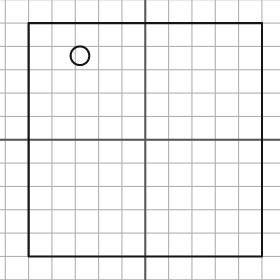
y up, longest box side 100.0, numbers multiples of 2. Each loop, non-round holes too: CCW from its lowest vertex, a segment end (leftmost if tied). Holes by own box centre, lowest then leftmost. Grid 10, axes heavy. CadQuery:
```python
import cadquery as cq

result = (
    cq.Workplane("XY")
    .moveTo(-50.0, -50.0)
    .lineTo(50.0, -50.0)
    .lineTo(50.0, 50.0)
    .lineTo(-50.0, 50.0)
    .close()
    .moveTo(-28.0, 36.0)
    .circle(4.0)
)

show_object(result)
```